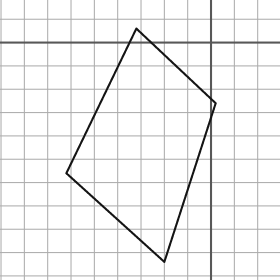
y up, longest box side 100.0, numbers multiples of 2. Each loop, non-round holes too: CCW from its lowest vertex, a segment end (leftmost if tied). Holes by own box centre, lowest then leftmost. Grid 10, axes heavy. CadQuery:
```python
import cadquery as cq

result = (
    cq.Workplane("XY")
    .moveTo(-20.0, -94.0)
    .lineTo(2.0, -26.0)
    .lineTo(-32.0, 6.0)
    .lineTo(-62.0, -56.0)
    .close()
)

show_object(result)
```